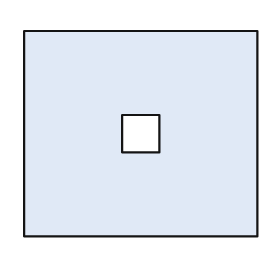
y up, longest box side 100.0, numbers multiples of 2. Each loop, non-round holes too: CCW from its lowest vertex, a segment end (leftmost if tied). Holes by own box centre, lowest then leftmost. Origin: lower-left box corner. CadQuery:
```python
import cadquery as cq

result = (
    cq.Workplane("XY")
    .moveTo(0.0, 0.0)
    .lineTo(100.0, 0.0)
    .lineTo(100.0, 88.0)
    .lineTo(0.0, 88.0)
    .close()
    .moveTo(42.0, 36.0)
    .lineTo(58.0, 36.0)
    .lineTo(58.0, 52.0)
    .lineTo(42.0, 52.0)
    .close()
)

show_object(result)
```